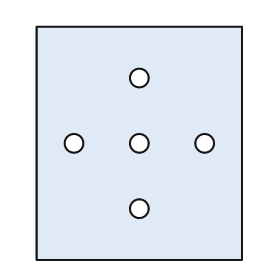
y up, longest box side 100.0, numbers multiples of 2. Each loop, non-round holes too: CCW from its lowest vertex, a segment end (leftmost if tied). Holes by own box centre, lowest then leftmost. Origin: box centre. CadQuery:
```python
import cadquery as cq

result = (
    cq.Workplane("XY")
    .moveTo(-44.0, -50.0)
    .lineTo(44.0, -50.0)
    .lineTo(44.0, 50.0)
    .lineTo(-44.0, 50.0)
    .close()
    .moveTo(0.0, -28.0)
    .circle(4.0)
    .moveTo(-28.0, 0.0)
    .circle(4.0)
    .moveTo(0.0, 0.0)
    .circle(4.0)
    .moveTo(28.0, 0.0)
    .circle(4.0)
    .moveTo(0.0, 28.0)
    .circle(4.0)
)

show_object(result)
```